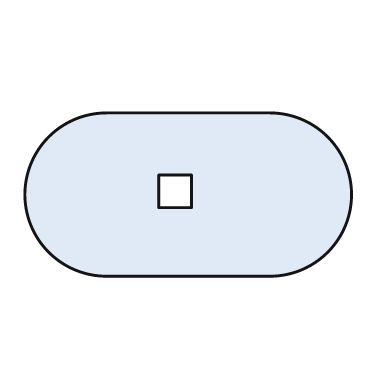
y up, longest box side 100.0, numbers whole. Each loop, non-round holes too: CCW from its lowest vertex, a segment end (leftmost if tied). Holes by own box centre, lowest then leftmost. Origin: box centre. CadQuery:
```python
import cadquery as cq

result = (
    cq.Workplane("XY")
    .moveTo(-25.0, -25.0)
    .lineTo(25.0, -25.0)
    .threePointArc((50.0, 0.0), (25.0, 25.0))
    .lineTo(-25.0, 25.0)
    .threePointArc((-50.0, 0.0), (-25.0, -25.0))
    .close()
    .moveTo(-9.0, -4.0)
    .lineTo(1.0, -4.0)
    .lineTo(1.0, 6.0)
    .lineTo(-9.0, 6.0)
    .close()
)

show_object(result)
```